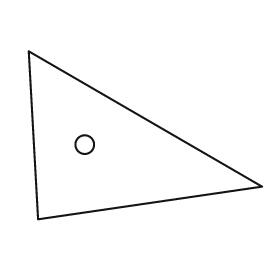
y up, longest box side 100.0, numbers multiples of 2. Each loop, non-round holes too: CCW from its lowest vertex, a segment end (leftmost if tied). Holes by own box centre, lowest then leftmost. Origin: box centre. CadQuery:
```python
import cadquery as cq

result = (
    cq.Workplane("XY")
    .moveTo(-46.0, -36.0)
    .lineTo(50.0, -22.0)
    .lineTo(-50.0, 36.0)
    .close()
    .moveTo(-26.0, -4.0)
    .circle(4.0)
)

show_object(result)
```